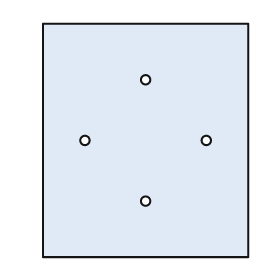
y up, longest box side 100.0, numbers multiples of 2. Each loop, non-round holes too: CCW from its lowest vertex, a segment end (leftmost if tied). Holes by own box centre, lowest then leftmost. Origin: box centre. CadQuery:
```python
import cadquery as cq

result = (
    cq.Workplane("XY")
    .moveTo(-44.0, -50.0)
    .lineTo(44.0, -50.0)
    .lineTo(44.0, 50.0)
    .lineTo(-44.0, 50.0)
    .close()
    .moveTo(0.0, -26.0)
    .circle(2.0)
    .moveTo(-26.0, 0.0)
    .circle(2.0)
    .moveTo(26.0, 0.0)
    .circle(2.0)
    .moveTo(0.0, 26.0)
    .circle(2.0)
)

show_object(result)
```